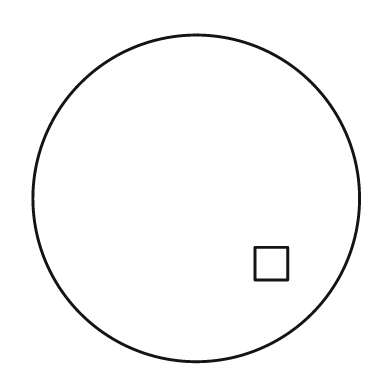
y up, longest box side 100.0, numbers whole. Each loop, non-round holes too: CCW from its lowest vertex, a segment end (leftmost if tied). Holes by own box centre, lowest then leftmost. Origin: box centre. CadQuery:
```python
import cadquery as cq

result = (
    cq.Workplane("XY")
    .moveTo(0.0, 0.0)
    .circle(50.0)
    .moveTo(18.0, -25.0)
    .lineTo(28.0, -25.0)
    .lineTo(28.0, -15.0)
    .lineTo(18.0, -15.0)
    .close()
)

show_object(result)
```